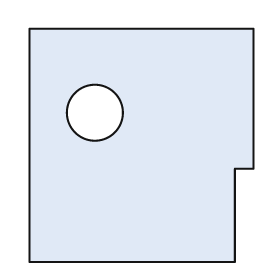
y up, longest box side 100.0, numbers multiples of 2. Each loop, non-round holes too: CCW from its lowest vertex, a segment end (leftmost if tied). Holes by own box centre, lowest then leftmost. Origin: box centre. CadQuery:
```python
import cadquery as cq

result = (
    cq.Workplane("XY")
    .moveTo(-48.0, -50.0)
    .lineTo(40.0, -50.0)
    .lineTo(40.0, -10.0)
    .lineTo(48.0, -10.0)
    .lineTo(48.0, 50.0)
    .lineTo(-48.0, 50.0)
    .close()
    .moveTo(-20.0, 14.0)
    .circle(12.0)
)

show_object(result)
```